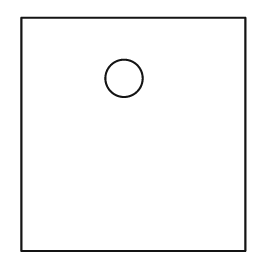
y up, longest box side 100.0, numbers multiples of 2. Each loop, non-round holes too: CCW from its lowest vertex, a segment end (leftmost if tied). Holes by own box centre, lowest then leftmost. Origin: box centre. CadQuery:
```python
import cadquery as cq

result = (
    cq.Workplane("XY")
    .moveTo(-48.0, -50.0)
    .lineTo(48.0, -50.0)
    .lineTo(48.0, 50.0)
    .lineTo(-48.0, 50.0)
    .close()
    .moveTo(-4.0, 24.0)
    .circle(8.0)
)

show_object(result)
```